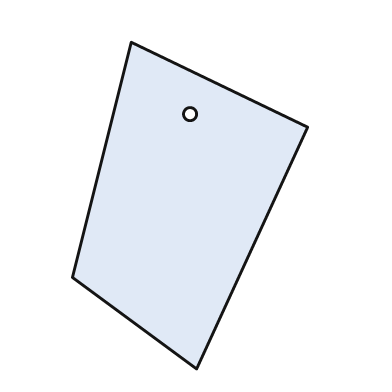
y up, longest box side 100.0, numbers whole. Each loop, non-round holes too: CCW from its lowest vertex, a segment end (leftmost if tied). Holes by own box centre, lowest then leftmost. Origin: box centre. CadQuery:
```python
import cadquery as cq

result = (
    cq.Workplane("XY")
    .moveTo(2.0, -50.0)
    .lineTo(36.0, 24.0)
    .lineTo(-18.0, 50.0)
    .lineTo(-36.0, -22.0)
    .close()
    .moveTo(0.0, 28.0)
    .circle(2.0)
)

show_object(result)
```